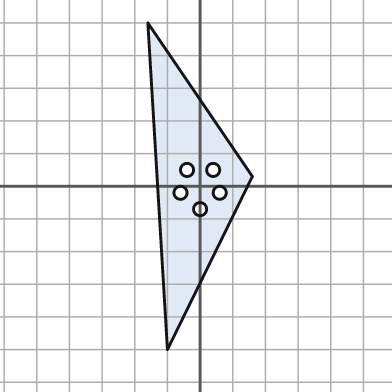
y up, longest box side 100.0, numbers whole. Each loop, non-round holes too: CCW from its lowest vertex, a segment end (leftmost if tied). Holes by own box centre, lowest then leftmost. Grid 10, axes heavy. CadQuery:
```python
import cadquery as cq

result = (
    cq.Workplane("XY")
    .moveTo(-10.0, -50.0)
    .lineTo(16.0, 3.0)
    .lineTo(-16.0, 50.0)
    .close()
    .moveTo(0.0, -7.0)
    .circle(2.0)
    .moveTo(-6.0, -2.0)
    .circle(2.0)
    .moveTo(6.0, -2.0)
    .circle(2.0)
    .moveTo(-4.0, 5.0)
    .circle(2.0)
    .moveTo(4.0, 5.0)
    .circle(2.0)
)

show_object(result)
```